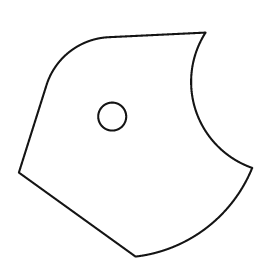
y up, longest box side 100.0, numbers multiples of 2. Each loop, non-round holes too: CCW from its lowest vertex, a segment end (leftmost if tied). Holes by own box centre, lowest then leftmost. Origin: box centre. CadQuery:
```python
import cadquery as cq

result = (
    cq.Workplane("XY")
    .moveTo(0.0, -48.0)
    .threePointArc((30.0, -36.0), (50.0, -10.0))
    .threePointArc((26.0, 14.0), (30.0, 48.0))
    .lineTo(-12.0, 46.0)
    .threePointArc((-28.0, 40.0), (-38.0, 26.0))
    .lineTo(-50.0, -12.0)
    .close()
    .moveTo(-10.0, 12.0)
    .circle(6.0)
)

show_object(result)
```